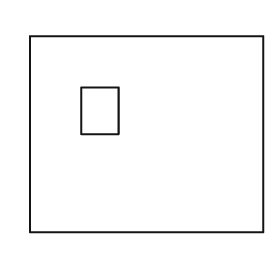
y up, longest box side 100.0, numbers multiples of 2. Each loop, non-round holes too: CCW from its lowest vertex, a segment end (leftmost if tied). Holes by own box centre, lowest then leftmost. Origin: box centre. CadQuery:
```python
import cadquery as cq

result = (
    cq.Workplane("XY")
    .moveTo(-50.0, -42.0)
    .lineTo(50.0, -42.0)
    .lineTo(50.0, 42.0)
    .lineTo(-50.0, 42.0)
    .close()
    .moveTo(-28.0, 0.0)
    .lineTo(-12.0, 0.0)
    .lineTo(-12.0, 20.0)
    .lineTo(-28.0, 20.0)
    .close()
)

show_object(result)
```